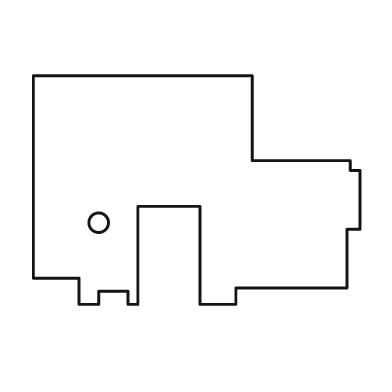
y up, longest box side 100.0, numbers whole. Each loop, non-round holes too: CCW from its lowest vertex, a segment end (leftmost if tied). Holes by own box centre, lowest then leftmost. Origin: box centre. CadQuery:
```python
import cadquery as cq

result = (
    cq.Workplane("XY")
    .moveTo(-36.0, -35.0)
    .lineTo(-30.0, -35.0)
    .lineTo(-30.0, -31.0)
    .lineTo(-21.0, -31.0)
    .lineTo(-21.0, -35.0)
    .lineTo(-18.0, -35.0)
    .lineTo(-18.0, -5.0)
    .lineTo(1.0, -5.0)
    .lineTo(1.0, -35.0)
    .lineTo(12.0, -35.0)
    .lineTo(12.0, -30.0)
    .lineTo(46.0, -30.0)
    .lineTo(46.0, -12.0)
    .lineTo(50.0, -12.0)
    .lineTo(50.0, 6.0)
    .lineTo(47.0, 6.0)
    .lineTo(47.0, 9.0)
    .lineTo(17.0, 9.0)
    .lineTo(17.0, 35.0)
    .lineTo(-50.0, 35.0)
    .lineTo(-50.0, -27.0)
    .lineTo(-36.0, -27.0)
    .close()
    .moveTo(-30.0, -10.0)
    .circle(3.0)
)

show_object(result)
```